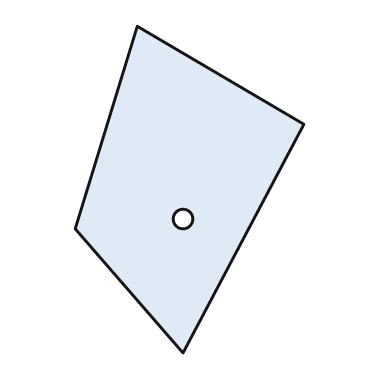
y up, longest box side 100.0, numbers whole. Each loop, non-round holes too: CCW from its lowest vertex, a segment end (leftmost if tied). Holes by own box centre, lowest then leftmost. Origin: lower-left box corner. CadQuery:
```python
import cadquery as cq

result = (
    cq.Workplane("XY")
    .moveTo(33.0, 0.0)
    .lineTo(70.0, 70.0)
    .lineTo(19.0, 100.0)
    .lineTo(0.0, 38.0)
    .close()
    .moveTo(33.0, 41.0)
    .circle(3.0)
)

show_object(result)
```